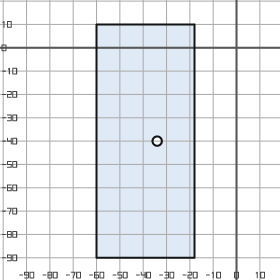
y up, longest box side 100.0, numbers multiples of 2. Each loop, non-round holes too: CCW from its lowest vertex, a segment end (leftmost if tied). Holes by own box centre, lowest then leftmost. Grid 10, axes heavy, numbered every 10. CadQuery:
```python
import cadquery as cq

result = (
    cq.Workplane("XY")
    .moveTo(-60.0, -90.0)
    .lineTo(-18.0, -90.0)
    .lineTo(-18.0, 10.0)
    .lineTo(-60.0, 10.0)
    .close()
    .moveTo(-34.0, -40.0)
    .circle(2.0)
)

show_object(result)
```